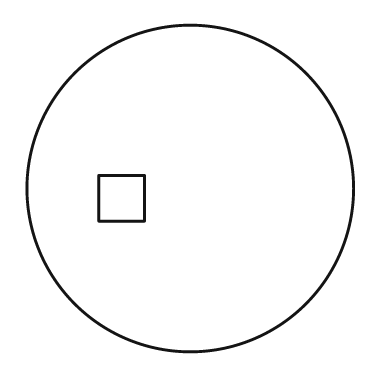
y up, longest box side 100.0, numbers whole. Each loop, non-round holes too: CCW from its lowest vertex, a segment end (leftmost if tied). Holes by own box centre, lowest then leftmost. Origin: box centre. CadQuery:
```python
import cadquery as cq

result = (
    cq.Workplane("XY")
    .moveTo(0.0, 0.0)
    .circle(50.0)
    .moveTo(-28.0, -10.0)
    .lineTo(-14.0, -10.0)
    .lineTo(-14.0, 4.0)
    .lineTo(-28.0, 4.0)
    .close()
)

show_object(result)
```